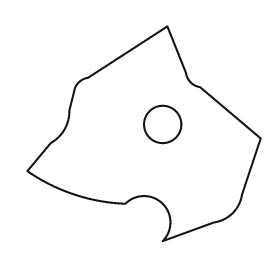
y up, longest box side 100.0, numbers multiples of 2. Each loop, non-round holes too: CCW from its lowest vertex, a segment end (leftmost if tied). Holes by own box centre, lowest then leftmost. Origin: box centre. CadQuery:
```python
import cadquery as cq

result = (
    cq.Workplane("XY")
    .moveTo(8.0, -46.0)
    .lineTo(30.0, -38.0)
    .threePointArc((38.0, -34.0), (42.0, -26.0))
    .lineTo(50.0, -2.0)
    .lineTo(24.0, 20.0)
    .threePointArc((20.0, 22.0), (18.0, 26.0))
    .lineTo(10.0, 46.0)
    .lineTo(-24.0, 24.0)
    .threePointArc((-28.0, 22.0), (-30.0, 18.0))
    .lineTo(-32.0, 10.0)
    .threePointArc((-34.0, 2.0), (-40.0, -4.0))
    .lineTo(-50.0, -16.0)
    .threePointArc((-30.0, -26.0), (-8.0, -30.0))
    .threePointArc((8.0, -30.0), (8.0, -46.0))
    .close()
    .moveTo(8.0, 4.0)
    .circle(8.0)
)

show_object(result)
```